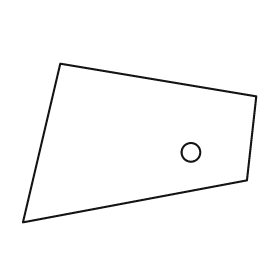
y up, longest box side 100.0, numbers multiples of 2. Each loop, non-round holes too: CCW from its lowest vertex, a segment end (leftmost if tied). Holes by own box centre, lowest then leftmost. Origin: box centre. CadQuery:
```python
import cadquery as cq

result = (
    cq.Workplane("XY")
    .moveTo(-50.0, -34.0)
    .lineTo(46.0, -16.0)
    .lineTo(50.0, 20.0)
    .lineTo(-34.0, 34.0)
    .close()
    .moveTo(22.0, -4.0)
    .circle(4.0)
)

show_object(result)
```